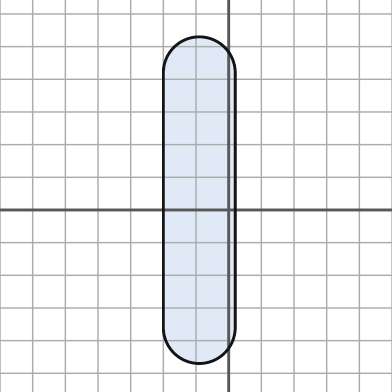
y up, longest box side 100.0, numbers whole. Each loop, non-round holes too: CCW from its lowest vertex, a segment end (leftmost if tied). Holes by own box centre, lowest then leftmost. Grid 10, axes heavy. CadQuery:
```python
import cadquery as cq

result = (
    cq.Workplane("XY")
    .moveTo(-20.0, -36.0)
    .threePointArc((-9.0, -47.0), (2.0, -36.0))
    .lineTo(2.0, 42.0)
    .threePointArc((-9.0, 53.0), (-20.0, 42.0))
    .close()
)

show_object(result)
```